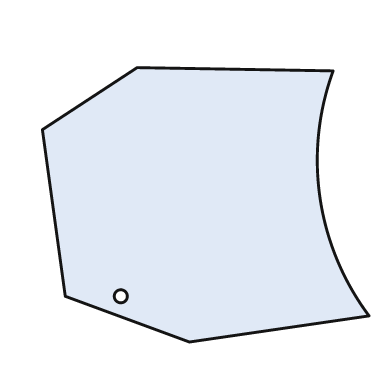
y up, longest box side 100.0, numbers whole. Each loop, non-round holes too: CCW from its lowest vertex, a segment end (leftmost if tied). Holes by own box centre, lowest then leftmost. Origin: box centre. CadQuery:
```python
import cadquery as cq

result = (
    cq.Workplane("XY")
    .moveTo(-5.0, -42.0)
    .lineTo(50.0, -34.0)
    .threePointArc((35.0, 2.0), (39.0, 41.0))
    .lineTo(-21.0, 42.0)
    .lineTo(-50.0, 23.0)
    .lineTo(-43.0, -28.0)
    .close()
    .moveTo(-26.0, -28.0)
    .circle(2.0)
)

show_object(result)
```